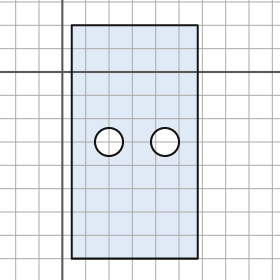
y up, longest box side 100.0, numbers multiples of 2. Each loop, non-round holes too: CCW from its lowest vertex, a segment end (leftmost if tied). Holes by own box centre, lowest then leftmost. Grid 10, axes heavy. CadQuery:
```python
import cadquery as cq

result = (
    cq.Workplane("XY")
    .moveTo(4.0, -80.0)
    .lineTo(58.0, -80.0)
    .lineTo(58.0, 20.0)
    .lineTo(4.0, 20.0)
    .close()
    .moveTo(20.0, -30.0)
    .circle(6.0)
    .moveTo(44.0, -30.0)
    .circle(6.0)
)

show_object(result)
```